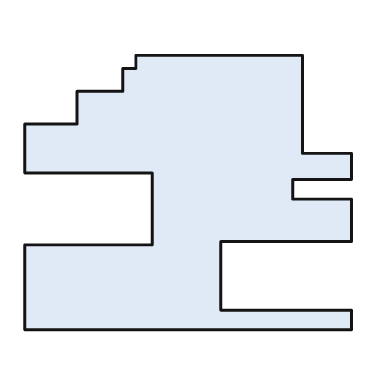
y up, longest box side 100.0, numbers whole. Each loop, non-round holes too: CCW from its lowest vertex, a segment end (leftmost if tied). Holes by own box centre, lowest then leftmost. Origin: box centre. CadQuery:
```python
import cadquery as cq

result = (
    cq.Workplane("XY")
    .moveTo(-50.0, -42.0)
    .lineTo(50.0, -42.0)
    .lineTo(50.0, -36.0)
    .lineTo(10.0, -36.0)
    .lineTo(10.0, -15.0)
    .lineTo(50.0, -15.0)
    .lineTo(50.0, -2.0)
    .lineTo(32.0, -2.0)
    .lineTo(32.0, 4.0)
    .lineTo(50.0, 4.0)
    .lineTo(50.0, 12.0)
    .lineTo(35.0, 12.0)
    .lineTo(35.0, 42.0)
    .lineTo(-16.0, 42.0)
    .lineTo(-16.0, 38.0)
    .lineTo(-20.0, 38.0)
    .lineTo(-20.0, 31.0)
    .lineTo(-34.0, 31.0)
    .lineTo(-34.0, 21.0)
    .lineTo(-50.0, 21.0)
    .lineTo(-50.0, 6.0)
    .lineTo(-11.0, 6.0)
    .lineTo(-11.0, -16.0)
    .lineTo(-50.0, -16.0)
    .close()
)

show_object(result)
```